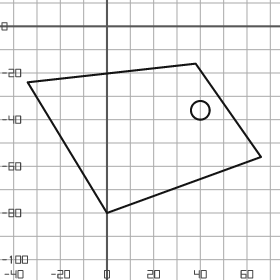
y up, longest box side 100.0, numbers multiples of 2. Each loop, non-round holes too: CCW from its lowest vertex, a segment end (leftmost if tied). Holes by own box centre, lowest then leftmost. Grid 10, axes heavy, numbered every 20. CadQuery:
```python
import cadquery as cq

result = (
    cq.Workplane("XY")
    .moveTo(0.0, -80.0)
    .lineTo(66.0, -56.0)
    .lineTo(38.0, -16.0)
    .lineTo(-34.0, -24.0)
    .close()
    .moveTo(40.0, -36.0)
    .circle(4.0)
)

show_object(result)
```